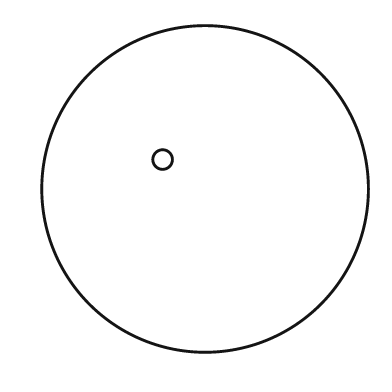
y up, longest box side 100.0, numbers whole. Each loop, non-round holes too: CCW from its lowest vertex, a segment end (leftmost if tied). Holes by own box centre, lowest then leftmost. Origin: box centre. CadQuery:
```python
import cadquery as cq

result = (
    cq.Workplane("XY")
    .moveTo(0.0, 0.0)
    .circle(50.0)
    .moveTo(-13.0, 9.0)
    .circle(3.0)
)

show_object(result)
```